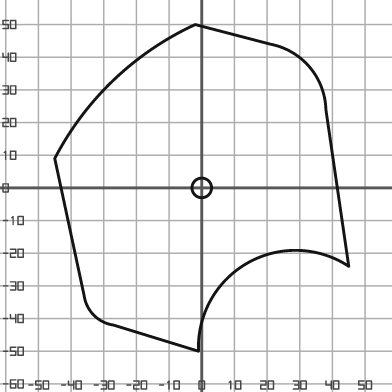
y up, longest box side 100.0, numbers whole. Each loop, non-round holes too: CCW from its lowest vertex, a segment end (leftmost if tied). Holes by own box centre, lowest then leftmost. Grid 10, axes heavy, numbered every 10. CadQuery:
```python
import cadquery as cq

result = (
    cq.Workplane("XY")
    .moveTo(-1.0, -50.0)
    .threePointArc((14.0, -23.0), (45.0, -24.0))
    .lineTo(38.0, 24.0)
    .threePointArc((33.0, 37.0), (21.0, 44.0))
    .lineTo(-2.0, 50.0)
    .threePointArc((-27.0, 33.0), (-45.0, 9.0))
    .lineTo(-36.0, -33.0)
    .threePointArc((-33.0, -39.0), (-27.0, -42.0))
    .close()
    .moveTo(0.0, 0.0)
    .circle(3.0)
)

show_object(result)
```